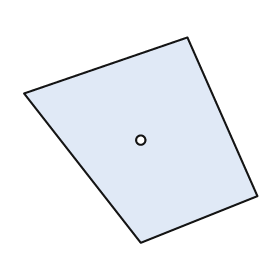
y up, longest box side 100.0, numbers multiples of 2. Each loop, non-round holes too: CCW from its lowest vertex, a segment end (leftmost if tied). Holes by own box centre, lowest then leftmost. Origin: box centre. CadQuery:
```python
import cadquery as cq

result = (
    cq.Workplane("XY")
    .moveTo(0.0, -44.0)
    .lineTo(50.0, -24.0)
    .lineTo(20.0, 44.0)
    .lineTo(-50.0, 20.0)
    .close()
    .moveTo(0.0, 0.0)
    .circle(2.0)
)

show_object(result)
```